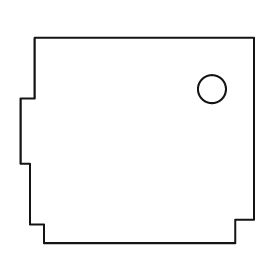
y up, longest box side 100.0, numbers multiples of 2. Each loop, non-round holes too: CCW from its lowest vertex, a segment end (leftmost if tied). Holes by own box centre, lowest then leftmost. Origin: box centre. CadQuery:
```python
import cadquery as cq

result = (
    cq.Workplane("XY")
    .moveTo(-40.0, -44.0)
    .lineTo(42.0, -44.0)
    .lineTo(42.0, -34.0)
    .lineTo(50.0, -34.0)
    .lineTo(50.0, 44.0)
    .lineTo(-44.0, 44.0)
    .lineTo(-44.0, 18.0)
    .lineTo(-50.0, 18.0)
    .lineTo(-50.0, -10.0)
    .lineTo(-46.0, -10.0)
    .lineTo(-46.0, -36.0)
    .lineTo(-40.0, -36.0)
    .close()
    .moveTo(32.0, 22.0)
    .circle(6.0)
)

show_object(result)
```